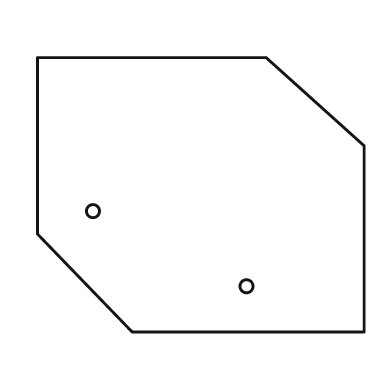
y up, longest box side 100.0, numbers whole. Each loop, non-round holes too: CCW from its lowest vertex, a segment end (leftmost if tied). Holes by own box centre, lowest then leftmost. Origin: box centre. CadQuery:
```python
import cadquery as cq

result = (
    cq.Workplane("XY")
    .moveTo(-21.0, -42.0)
    .lineTo(50.0, -42.0)
    .lineTo(50.0, 15.0)
    .lineTo(20.0, 42.0)
    .lineTo(-50.0, 42.0)
    .lineTo(-50.0, -12.0)
    .close()
    .moveTo(14.0, -28.0)
    .circle(2.0)
    .moveTo(-33.0, -5.0)
    .circle(2.0)
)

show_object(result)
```